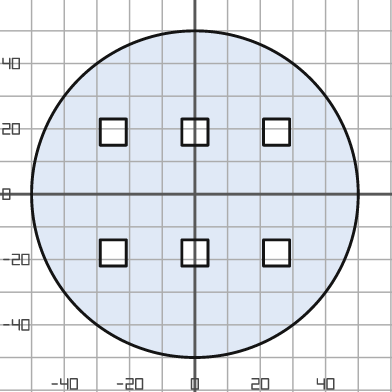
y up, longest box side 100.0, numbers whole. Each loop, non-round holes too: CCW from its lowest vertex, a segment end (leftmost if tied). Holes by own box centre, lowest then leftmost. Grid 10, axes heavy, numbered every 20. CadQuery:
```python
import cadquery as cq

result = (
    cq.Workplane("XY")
    .moveTo(0.0, 0.0)
    .circle(50.0)
    .moveTo(-29.0, -22.0)
    .lineTo(-21.0, -22.0)
    .lineTo(-21.0, -14.0)
    .lineTo(-29.0, -14.0)
    .close()
    .moveTo(-4.0, -22.0)
    .lineTo(4.0, -22.0)
    .lineTo(4.0, -14.0)
    .lineTo(-4.0, -14.0)
    .close()
    .moveTo(21.0, -22.0)
    .lineTo(29.0, -22.0)
    .lineTo(29.0, -14.0)
    .lineTo(21.0, -14.0)
    .close()
    .moveTo(-29.0, 15.0)
    .lineTo(-21.0, 15.0)
    .lineTo(-21.0, 23.0)
    .lineTo(-29.0, 23.0)
    .close()
    .moveTo(-4.0, 15.0)
    .lineTo(4.0, 15.0)
    .lineTo(4.0, 23.0)
    .lineTo(-4.0, 23.0)
    .close()
    .moveTo(21.0, 15.0)
    .lineTo(29.0, 15.0)
    .lineTo(29.0, 23.0)
    .lineTo(21.0, 23.0)
    .close()
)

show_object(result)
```